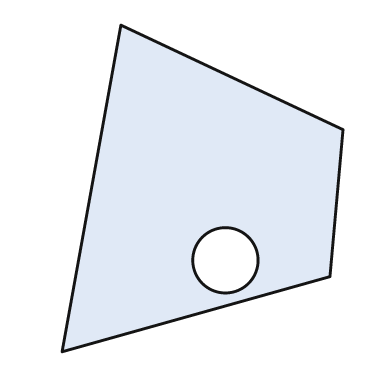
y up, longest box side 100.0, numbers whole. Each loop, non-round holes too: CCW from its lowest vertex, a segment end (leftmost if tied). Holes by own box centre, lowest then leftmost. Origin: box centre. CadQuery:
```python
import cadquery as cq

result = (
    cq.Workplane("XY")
    .moveTo(-43.0, -50.0)
    .lineTo(39.0, -27.0)
    .lineTo(43.0, 18.0)
    .lineTo(-25.0, 50.0)
    .close()
    .moveTo(7.0, -22.0)
    .circle(10.0)
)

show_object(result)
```